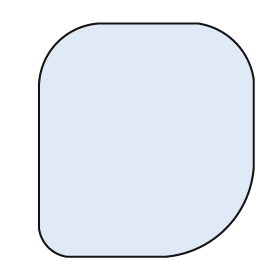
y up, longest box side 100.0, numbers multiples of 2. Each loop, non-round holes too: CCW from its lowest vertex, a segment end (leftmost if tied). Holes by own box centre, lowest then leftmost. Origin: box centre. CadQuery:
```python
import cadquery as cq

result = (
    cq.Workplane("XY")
    .moveTo(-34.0, -50.0)
    .lineTo(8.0, -50.0)
    .threePointArc((34.0, -38.0), (46.0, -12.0))
    .lineTo(46.0, 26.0)
    .threePointArc((38.0, 42.0), (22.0, 50.0))
    .lineTo(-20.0, 50.0)
    .threePointArc((-38.0, 42.0), (-46.0, 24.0))
    .lineTo(-46.0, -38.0)
    .threePointArc((-42.0, -46.0), (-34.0, -50.0))
    .close()
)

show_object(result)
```